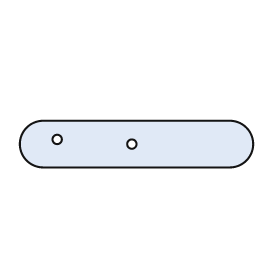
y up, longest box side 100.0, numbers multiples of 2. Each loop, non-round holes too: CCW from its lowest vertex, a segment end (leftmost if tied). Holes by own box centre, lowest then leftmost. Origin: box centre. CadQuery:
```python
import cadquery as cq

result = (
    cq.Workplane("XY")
    .moveTo(-40.0, -10.0)
    .lineTo(40.0, -10.0)
    .threePointArc((50.0, 0.0), (40.0, 10.0))
    .lineTo(-40.0, 10.0)
    .threePointArc((-50.0, 0.0), (-40.0, -10.0))
    .close()
    .moveTo(-2.0, 0.0)
    .circle(2.0)
    .moveTo(-34.0, 2.0)
    .circle(2.0)
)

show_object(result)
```